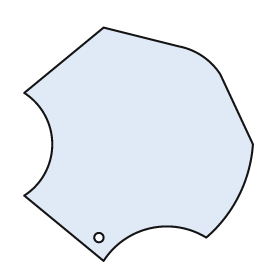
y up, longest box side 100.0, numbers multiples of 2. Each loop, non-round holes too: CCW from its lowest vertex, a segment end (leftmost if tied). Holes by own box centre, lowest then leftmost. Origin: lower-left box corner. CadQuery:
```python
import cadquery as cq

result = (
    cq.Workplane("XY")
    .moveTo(34.0, 0.0)
    .threePointArc((54.0, 14.0), (78.0, 10.0))
    .threePointArc((92.0, 28.0), (98.0, 50.0))
    .lineTo(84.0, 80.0)
    .threePointArc((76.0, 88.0), (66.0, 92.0))
    .lineTo(34.0, 100.0)
    .lineTo(0.0, 72.0)
    .threePointArc((12.0, 50.0), (0.0, 28.0))
    .close()
    .moveTo(32.0, 10.0)
    .circle(2.0)
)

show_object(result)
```